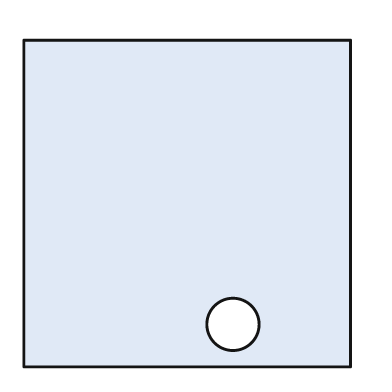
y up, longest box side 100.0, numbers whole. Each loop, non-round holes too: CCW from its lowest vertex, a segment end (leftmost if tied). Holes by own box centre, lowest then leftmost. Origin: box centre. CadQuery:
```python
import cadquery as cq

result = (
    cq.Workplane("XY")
    .moveTo(-50.0, -50.0)
    .lineTo(50.0, -50.0)
    .lineTo(50.0, 50.0)
    .lineTo(-50.0, 50.0)
    .close()
    .moveTo(14.0, -37.0)
    .circle(8.0)
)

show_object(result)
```